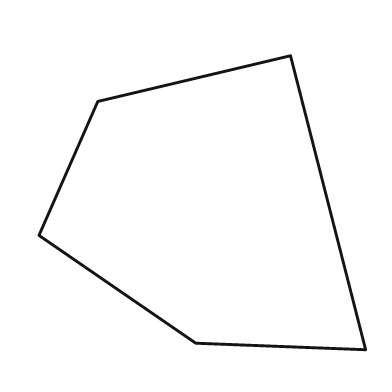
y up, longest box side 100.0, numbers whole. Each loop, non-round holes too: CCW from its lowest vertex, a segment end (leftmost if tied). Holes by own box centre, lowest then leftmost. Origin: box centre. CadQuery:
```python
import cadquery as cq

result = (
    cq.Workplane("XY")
    .moveTo(50.0, -45.0)
    .lineTo(27.0, 45.0)
    .lineTo(-32.0, 31.0)
    .lineTo(-50.0, -10.0)
    .lineTo(-2.0, -43.0)
    .close()
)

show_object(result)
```